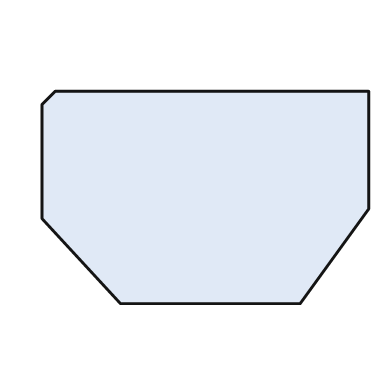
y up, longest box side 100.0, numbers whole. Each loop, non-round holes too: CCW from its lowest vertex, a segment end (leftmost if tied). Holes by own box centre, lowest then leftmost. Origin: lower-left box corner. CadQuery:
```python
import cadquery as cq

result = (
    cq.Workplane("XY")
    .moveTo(24.0, 0.0)
    .lineTo(79.0, 0.0)
    .lineTo(100.0, 29.0)
    .lineTo(100.0, 65.0)
    .lineTo(4.0, 65.0)
    .lineTo(0.0, 61.0)
    .lineTo(0.0, 26.0)
    .close()
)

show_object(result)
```